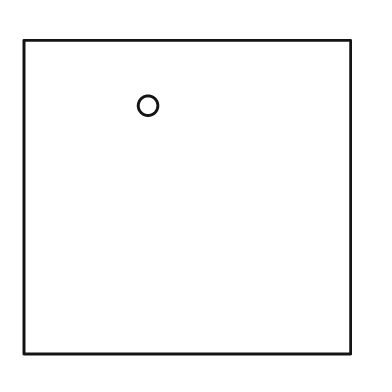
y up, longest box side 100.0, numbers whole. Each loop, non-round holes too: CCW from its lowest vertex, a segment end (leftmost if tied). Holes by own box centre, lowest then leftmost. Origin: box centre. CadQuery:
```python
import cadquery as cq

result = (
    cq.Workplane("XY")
    .moveTo(-50.0, -48.0)
    .lineTo(50.0, -48.0)
    .lineTo(50.0, 48.0)
    .lineTo(-50.0, 48.0)
    .close()
    .moveTo(-12.0, 28.0)
    .circle(3.0)
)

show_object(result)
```